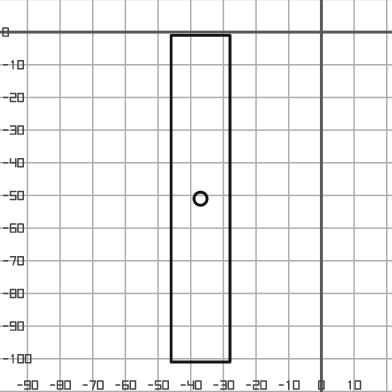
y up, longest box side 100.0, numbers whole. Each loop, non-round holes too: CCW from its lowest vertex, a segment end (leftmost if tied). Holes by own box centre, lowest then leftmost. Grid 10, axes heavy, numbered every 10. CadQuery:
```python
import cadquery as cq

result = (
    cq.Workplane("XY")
    .moveTo(-46.0, -101.0)
    .lineTo(-28.0, -101.0)
    .lineTo(-28.0, -1.0)
    .lineTo(-46.0, -1.0)
    .close()
    .moveTo(-37.0, -51.0)
    .circle(2.0)
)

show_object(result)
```